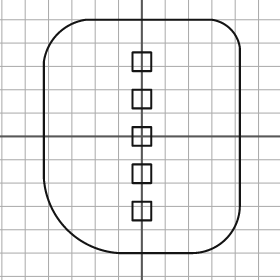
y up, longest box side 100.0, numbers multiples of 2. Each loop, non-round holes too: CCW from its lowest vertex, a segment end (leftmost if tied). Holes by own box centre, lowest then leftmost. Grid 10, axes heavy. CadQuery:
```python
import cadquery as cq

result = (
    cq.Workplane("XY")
    .moveTo(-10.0, -50.0)
    .lineTo(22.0, -50.0)
    .threePointArc((36.0, -44.0), (42.0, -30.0))
    .lineTo(42.0, 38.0)
    .threePointArc((38.0, 46.0), (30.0, 50.0))
    .lineTo(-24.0, 50.0)
    .threePointArc((-36.0, 44.0), (-42.0, 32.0))
    .lineTo(-42.0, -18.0)
    .threePointArc((-32.0, -40.0), (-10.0, -50.0))
    .close()
    .moveTo(-4.0, -36.0)
    .lineTo(4.0, -36.0)
    .lineTo(4.0, -28.0)
    .lineTo(-4.0, -28.0)
    .close()
    .moveTo(-4.0, -20.0)
    .lineTo(4.0, -20.0)
    .lineTo(4.0, -12.0)
    .lineTo(-4.0, -12.0)
    .close()
    .moveTo(-4.0, -4.0)
    .lineTo(4.0, -4.0)
    .lineTo(4.0, 4.0)
    .lineTo(-4.0, 4.0)
    .close()
    .moveTo(-4.0, 12.0)
    .lineTo(4.0, 12.0)
    .lineTo(4.0, 20.0)
    .lineTo(-4.0, 20.0)
    .close()
    .moveTo(-4.0, 28.0)
    .lineTo(4.0, 28.0)
    .lineTo(4.0, 36.0)
    .lineTo(-4.0, 36.0)
    .close()
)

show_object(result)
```